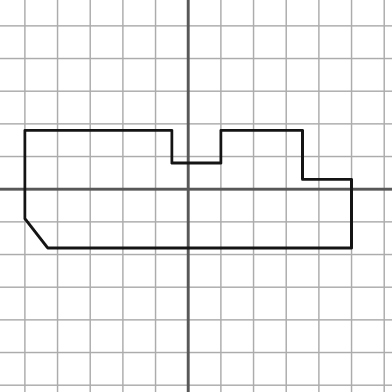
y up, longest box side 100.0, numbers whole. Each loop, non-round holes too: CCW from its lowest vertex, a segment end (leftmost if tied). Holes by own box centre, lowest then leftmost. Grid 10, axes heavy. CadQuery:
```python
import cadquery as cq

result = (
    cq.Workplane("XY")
    .moveTo(-43.0, -18.0)
    .lineTo(50.0, -18.0)
    .lineTo(50.0, 3.0)
    .lineTo(35.0, 3.0)
    .lineTo(35.0, 18.0)
    .lineTo(10.0, 18.0)
    .lineTo(10.0, 8.0)
    .lineTo(-5.0, 8.0)
    .lineTo(-5.0, 18.0)
    .lineTo(-50.0, 18.0)
    .lineTo(-50.0, -9.0)
    .close()
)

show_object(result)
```